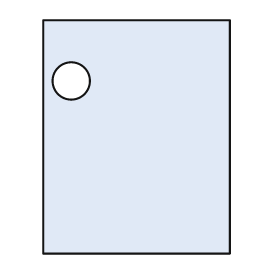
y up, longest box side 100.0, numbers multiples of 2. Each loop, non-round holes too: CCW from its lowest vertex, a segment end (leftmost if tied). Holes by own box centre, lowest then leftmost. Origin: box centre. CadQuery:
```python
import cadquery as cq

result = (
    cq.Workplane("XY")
    .moveTo(-40.0, -50.0)
    .lineTo(40.0, -50.0)
    .lineTo(40.0, 50.0)
    .lineTo(-40.0, 50.0)
    .close()
    .moveTo(-28.0, 24.0)
    .circle(8.0)
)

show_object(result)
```